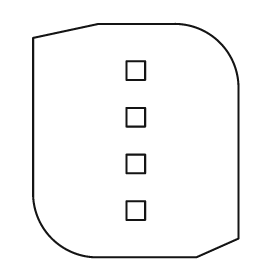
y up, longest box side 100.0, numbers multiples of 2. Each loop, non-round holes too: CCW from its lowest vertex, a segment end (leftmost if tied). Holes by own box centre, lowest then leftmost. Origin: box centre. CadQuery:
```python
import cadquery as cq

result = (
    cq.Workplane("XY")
    .moveTo(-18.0, -50.0)
    .lineTo(26.0, -50.0)
    .lineTo(44.0, -42.0)
    .lineTo(44.0, 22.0)
    .threePointArc((36.0, 42.0), (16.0, 50.0))
    .lineTo(-16.0, 50.0)
    .lineTo(-44.0, 44.0)
    .lineTo(-44.0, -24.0)
    .threePointArc((-36.0, -42.0), (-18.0, -50.0))
    .close()
    .moveTo(-4.0, -34.0)
    .lineTo(4.0, -34.0)
    .lineTo(4.0, -26.0)
    .lineTo(-4.0, -26.0)
    .close()
    .moveTo(-4.0, -14.0)
    .lineTo(4.0, -14.0)
    .lineTo(4.0, -6.0)
    .lineTo(-4.0, -6.0)
    .close()
    .moveTo(-4.0, 6.0)
    .lineTo(4.0, 6.0)
    .lineTo(4.0, 14.0)
    .lineTo(-4.0, 14.0)
    .close()
    .moveTo(-4.0, 26.0)
    .lineTo(4.0, 26.0)
    .lineTo(4.0, 34.0)
    .lineTo(-4.0, 34.0)
    .close()
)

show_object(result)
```